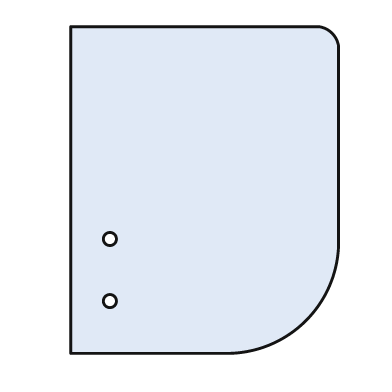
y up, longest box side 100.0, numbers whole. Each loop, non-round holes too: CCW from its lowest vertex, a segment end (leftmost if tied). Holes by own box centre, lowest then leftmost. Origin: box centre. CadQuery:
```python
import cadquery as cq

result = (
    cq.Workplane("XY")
    .moveTo(-41.0, -50.0)
    .lineTo(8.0, -50.0)
    .threePointArc((31.0, -40.0), (41.0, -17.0))
    .lineTo(41.0, 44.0)
    .threePointArc((39.0, 48.0), (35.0, 50.0))
    .lineTo(-41.0, 50.0)
    .close()
    .moveTo(-29.0, -34.0)
    .circle(2.0)
    .moveTo(-29.0, -15.0)
    .circle(2.0)
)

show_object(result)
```